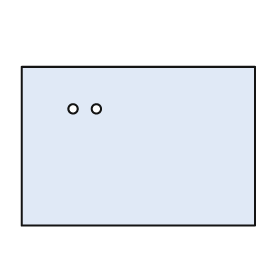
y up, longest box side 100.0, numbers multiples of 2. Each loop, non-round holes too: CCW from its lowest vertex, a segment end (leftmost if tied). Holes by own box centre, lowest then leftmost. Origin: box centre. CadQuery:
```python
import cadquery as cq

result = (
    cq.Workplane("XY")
    .moveTo(-50.0, -34.0)
    .lineTo(50.0, -34.0)
    .lineTo(50.0, 34.0)
    .lineTo(-50.0, 34.0)
    .close()
    .moveTo(-28.0, 16.0)
    .circle(2.0)
    .moveTo(-18.0, 16.0)
    .circle(2.0)
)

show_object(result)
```